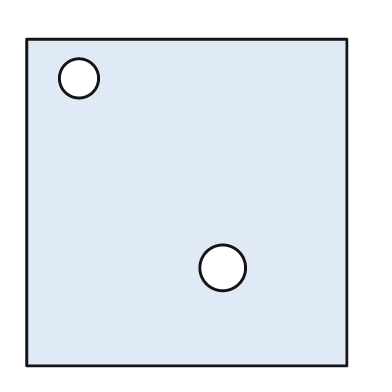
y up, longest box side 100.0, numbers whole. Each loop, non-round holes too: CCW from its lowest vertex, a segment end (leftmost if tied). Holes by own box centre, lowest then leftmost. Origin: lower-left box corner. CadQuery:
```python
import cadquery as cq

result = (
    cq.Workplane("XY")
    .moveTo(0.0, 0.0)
    .lineTo(98.0, 0.0)
    .lineTo(98.0, 100.0)
    .lineTo(0.0, 100.0)
    .close()
    .moveTo(60.0, 30.0)
    .circle(7.0)
    .moveTo(16.0, 88.0)
    .circle(6.0)
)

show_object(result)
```